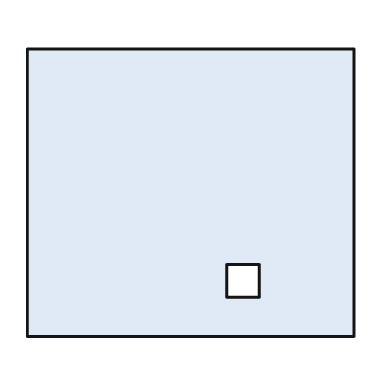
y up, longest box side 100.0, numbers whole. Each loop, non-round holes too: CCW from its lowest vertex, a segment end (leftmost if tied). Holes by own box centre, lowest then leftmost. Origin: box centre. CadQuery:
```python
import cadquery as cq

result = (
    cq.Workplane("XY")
    .moveTo(-50.0, -44.0)
    .lineTo(50.0, -44.0)
    .lineTo(50.0, 44.0)
    .lineTo(-50.0, 44.0)
    .close()
    .moveTo(11.0, -32.0)
    .lineTo(21.0, -32.0)
    .lineTo(21.0, -22.0)
    .lineTo(11.0, -22.0)
    .close()
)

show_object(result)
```